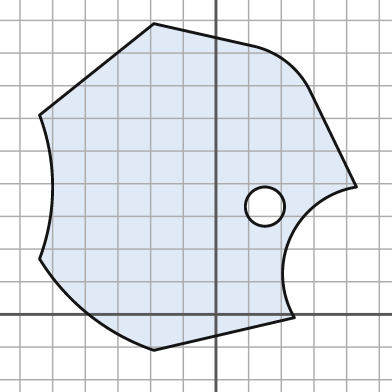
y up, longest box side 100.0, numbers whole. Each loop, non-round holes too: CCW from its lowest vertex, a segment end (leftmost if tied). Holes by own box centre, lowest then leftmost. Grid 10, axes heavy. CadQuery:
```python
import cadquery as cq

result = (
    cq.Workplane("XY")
    .moveTo(-19.0, -11.0)
    .lineTo(24.0, -1.0)
    .threePointArc((23.0, 24.0), (43.0, 39.0))
    .lineTo(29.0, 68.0)
    .threePointArc((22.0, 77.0), (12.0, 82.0))
    .lineTo(-19.0, 89.0)
    .lineTo(-54.0, 61.0)
    .threePointArc((-50.0, 39.0), (-54.0, 17.0))
    .threePointArc((-39.0, 0.0), (-19.0, -11.0))
    .close()
    .moveTo(15.0, 33.0)
    .circle(6.0)
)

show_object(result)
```